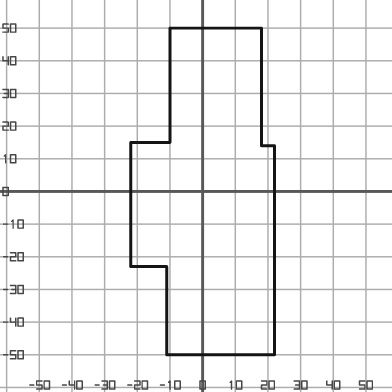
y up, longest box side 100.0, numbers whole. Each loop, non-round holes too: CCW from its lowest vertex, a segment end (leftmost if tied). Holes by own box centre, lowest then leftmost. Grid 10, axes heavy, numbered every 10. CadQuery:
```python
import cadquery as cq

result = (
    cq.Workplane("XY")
    .moveTo(-11.0, -50.0)
    .lineTo(22.0, -50.0)
    .lineTo(22.0, 14.0)
    .lineTo(18.0, 14.0)
    .lineTo(18.0, 50.0)
    .lineTo(-10.0, 50.0)
    .lineTo(-10.0, 15.0)
    .lineTo(-22.0, 15.0)
    .lineTo(-22.0, -23.0)
    .lineTo(-11.0, -23.0)
    .close()
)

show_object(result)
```